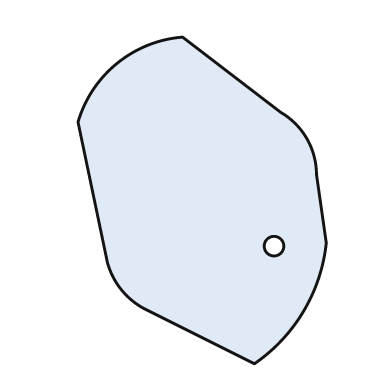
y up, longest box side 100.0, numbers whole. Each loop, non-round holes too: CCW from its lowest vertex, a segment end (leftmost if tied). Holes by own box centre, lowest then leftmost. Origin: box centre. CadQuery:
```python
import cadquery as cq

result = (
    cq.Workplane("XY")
    .moveTo(16.0, -50.0)
    .threePointArc((31.0, -34.0), (38.0, -13.0))
    .lineTo(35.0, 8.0)
    .threePointArc((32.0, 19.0), (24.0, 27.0))
    .lineTo(-6.0, 50.0)
    .threePointArc((-26.0, 42.0), (-38.0, 24.0))
    .lineTo(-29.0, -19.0)
    .threePointArc((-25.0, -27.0), (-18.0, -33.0))
    .close()
    .moveTo(22.0, -14.0)
    .circle(3.0)
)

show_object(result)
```